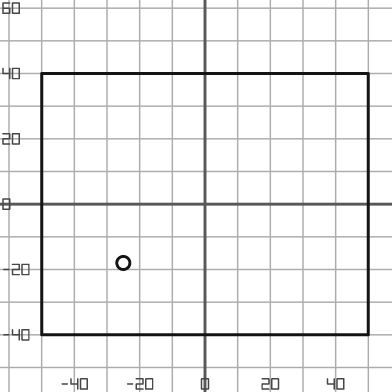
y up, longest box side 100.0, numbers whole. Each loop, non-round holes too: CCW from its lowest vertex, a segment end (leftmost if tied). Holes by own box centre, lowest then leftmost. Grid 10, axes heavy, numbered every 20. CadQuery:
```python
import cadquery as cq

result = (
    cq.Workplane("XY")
    .moveTo(-50.0, -40.0)
    .lineTo(50.0, -40.0)
    .lineTo(50.0, 40.0)
    .lineTo(-50.0, 40.0)
    .close()
    .moveTo(-25.0, -18.0)
    .circle(2.0)
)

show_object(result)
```